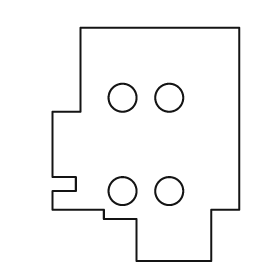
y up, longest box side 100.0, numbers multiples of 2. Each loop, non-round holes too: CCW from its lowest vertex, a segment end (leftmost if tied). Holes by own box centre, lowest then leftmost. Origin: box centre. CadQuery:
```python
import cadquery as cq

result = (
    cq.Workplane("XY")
    .moveTo(-4.0, -50.0)
    .lineTo(28.0, -50.0)
    .lineTo(28.0, -28.0)
    .lineTo(40.0, -28.0)
    .lineTo(40.0, 50.0)
    .lineTo(-28.0, 50.0)
    .lineTo(-28.0, 14.0)
    .lineTo(-40.0, 14.0)
    .lineTo(-40.0, -14.0)
    .lineTo(-30.0, -14.0)
    .lineTo(-30.0, -20.0)
    .lineTo(-40.0, -20.0)
    .lineTo(-40.0, -28.0)
    .lineTo(-18.0, -28.0)
    .lineTo(-18.0, -32.0)
    .lineTo(-4.0, -32.0)
    .close()
    .moveTo(-10.0, -20.0)
    .circle(6.0)
    .moveTo(10.0, -20.0)
    .circle(6.0)
    .moveTo(-10.0, 20.0)
    .circle(6.0)
    .moveTo(10.0, 20.0)
    .circle(6.0)
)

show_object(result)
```